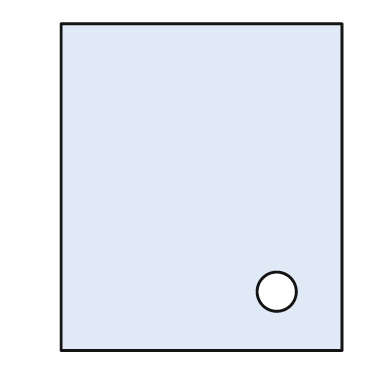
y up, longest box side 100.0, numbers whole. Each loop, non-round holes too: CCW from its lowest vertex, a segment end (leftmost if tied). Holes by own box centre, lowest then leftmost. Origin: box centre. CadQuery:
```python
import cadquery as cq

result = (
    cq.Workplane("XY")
    .moveTo(-43.0, -50.0)
    .lineTo(43.0, -50.0)
    .lineTo(43.0, 50.0)
    .lineTo(-43.0, 50.0)
    .close()
    .moveTo(23.0, -32.0)
    .circle(6.0)
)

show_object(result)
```